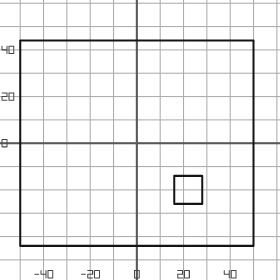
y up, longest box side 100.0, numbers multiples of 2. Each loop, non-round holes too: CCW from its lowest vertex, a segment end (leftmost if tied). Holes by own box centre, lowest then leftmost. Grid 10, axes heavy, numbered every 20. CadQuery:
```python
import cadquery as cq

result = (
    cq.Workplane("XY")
    .moveTo(-50.0, -44.0)
    .lineTo(50.0, -44.0)
    .lineTo(50.0, 44.0)
    .lineTo(-50.0, 44.0)
    .close()
    .moveTo(16.0, -26.0)
    .lineTo(28.0, -26.0)
    .lineTo(28.0, -14.0)
    .lineTo(16.0, -14.0)
    .close()
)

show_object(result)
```